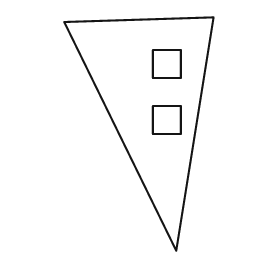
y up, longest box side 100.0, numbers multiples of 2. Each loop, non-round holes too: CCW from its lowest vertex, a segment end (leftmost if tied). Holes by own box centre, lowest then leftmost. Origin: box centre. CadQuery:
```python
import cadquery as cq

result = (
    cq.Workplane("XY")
    .moveTo(16.0, -50.0)
    .lineTo(32.0, 50.0)
    .lineTo(-32.0, 48.0)
    .close()
    .moveTo(6.0, 0.0)
    .lineTo(18.0, 0.0)
    .lineTo(18.0, 12.0)
    .lineTo(6.0, 12.0)
    .close()
    .moveTo(6.0, 24.0)
    .lineTo(18.0, 24.0)
    .lineTo(18.0, 36.0)
    .lineTo(6.0, 36.0)
    .close()
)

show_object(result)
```